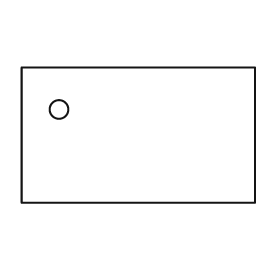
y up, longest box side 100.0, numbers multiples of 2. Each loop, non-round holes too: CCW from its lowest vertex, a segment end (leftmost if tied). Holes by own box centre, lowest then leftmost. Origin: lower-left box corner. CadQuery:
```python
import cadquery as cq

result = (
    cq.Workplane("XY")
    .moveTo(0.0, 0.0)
    .lineTo(100.0, 0.0)
    .lineTo(100.0, 58.0)
    .lineTo(0.0, 58.0)
    .close()
    .moveTo(16.0, 40.0)
    .circle(4.0)
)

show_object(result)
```